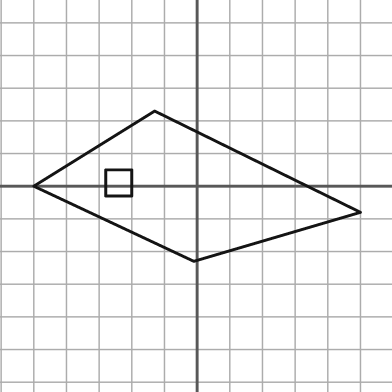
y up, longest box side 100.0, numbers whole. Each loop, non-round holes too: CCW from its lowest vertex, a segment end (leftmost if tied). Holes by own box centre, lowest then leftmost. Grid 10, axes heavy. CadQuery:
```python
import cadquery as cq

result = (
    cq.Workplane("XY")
    .moveTo(-1.0, -23.0)
    .lineTo(50.0, -8.0)
    .lineTo(-13.0, 23.0)
    .lineTo(-50.0, 0.0)
    .close()
    .moveTo(-28.0, -3.0)
    .lineTo(-20.0, -3.0)
    .lineTo(-20.0, 5.0)
    .lineTo(-28.0, 5.0)
    .close()
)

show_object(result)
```